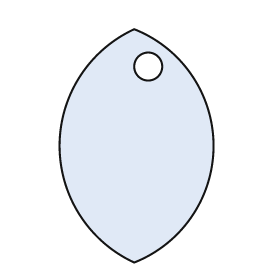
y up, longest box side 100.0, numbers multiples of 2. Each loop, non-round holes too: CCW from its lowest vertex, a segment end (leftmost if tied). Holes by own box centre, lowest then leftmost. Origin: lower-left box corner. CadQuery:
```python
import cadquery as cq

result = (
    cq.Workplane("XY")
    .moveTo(32.0, 0.0)
    .threePointArc((66.0, 50.0), (32.0, 100.0))
    .threePointArc((0.0, 50.0), (32.0, 0.0))
    .close()
    .moveTo(38.0, 84.0)
    .circle(6.0)
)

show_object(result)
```